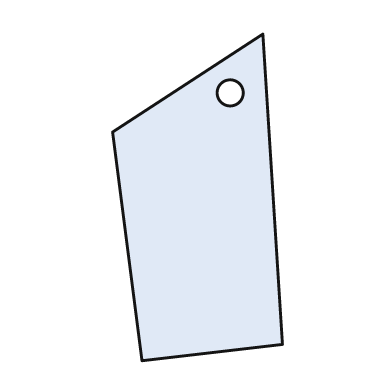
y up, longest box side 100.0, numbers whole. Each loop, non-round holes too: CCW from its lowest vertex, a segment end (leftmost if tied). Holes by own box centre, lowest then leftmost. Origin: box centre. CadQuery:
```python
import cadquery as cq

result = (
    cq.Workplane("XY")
    .moveTo(-17.0, -50.0)
    .lineTo(26.0, -45.0)
    .lineTo(20.0, 50.0)
    .lineTo(-26.0, 20.0)
    .close()
    .moveTo(10.0, 32.0)
    .circle(4.0)
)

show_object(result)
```